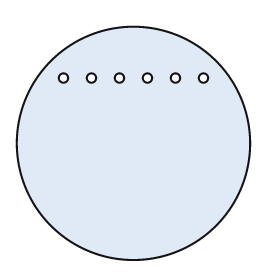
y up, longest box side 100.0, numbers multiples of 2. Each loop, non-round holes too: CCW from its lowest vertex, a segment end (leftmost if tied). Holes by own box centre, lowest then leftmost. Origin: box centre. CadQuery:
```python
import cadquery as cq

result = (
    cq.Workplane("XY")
    .moveTo(0.0, 0.0)
    .circle(50.0)
    .moveTo(-30.0, 28.0)
    .circle(2.0)
    .moveTo(-18.0, 28.0)
    .circle(2.0)
    .moveTo(-6.0, 28.0)
    .circle(2.0)
    .moveTo(6.0, 28.0)
    .circle(2.0)
    .moveTo(18.0, 28.0)
    .circle(2.0)
    .moveTo(30.0, 28.0)
    .circle(2.0)
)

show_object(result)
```